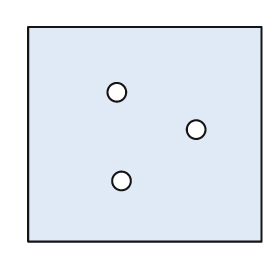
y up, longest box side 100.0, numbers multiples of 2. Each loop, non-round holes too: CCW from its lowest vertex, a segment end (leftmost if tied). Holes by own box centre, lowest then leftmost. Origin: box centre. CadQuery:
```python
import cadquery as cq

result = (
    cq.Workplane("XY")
    .moveTo(-50.0, -46.0)
    .lineTo(50.0, -46.0)
    .lineTo(50.0, 46.0)
    .lineTo(-50.0, 46.0)
    .close()
    .moveTo(-10.0, -20.0)
    .circle(4.0)
    .moveTo(22.0, 2.0)
    .circle(4.0)
    .moveTo(-12.0, 18.0)
    .circle(4.0)
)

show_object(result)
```